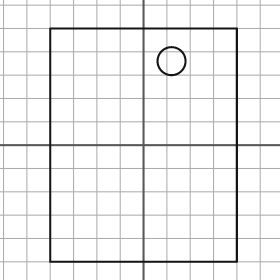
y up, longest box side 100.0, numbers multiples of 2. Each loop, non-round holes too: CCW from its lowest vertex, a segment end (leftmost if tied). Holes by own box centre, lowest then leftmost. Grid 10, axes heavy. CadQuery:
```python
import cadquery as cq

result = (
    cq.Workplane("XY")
    .moveTo(-40.0, -50.0)
    .lineTo(40.0, -50.0)
    .lineTo(40.0, 50.0)
    .lineTo(-40.0, 50.0)
    .close()
    .moveTo(12.0, 36.0)
    .circle(6.0)
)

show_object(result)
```